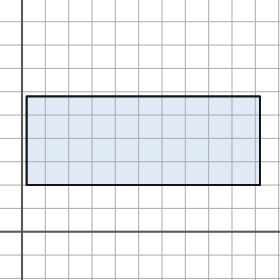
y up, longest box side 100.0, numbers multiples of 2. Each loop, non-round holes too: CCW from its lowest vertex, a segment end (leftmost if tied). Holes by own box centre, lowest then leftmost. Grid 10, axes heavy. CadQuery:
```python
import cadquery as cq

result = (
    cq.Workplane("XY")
    .moveTo(2.0, 20.0)
    .lineTo(102.0, 20.0)
    .lineTo(102.0, 58.0)
    .lineTo(2.0, 58.0)
    .close()
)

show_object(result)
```